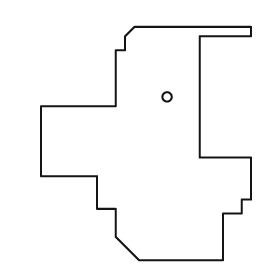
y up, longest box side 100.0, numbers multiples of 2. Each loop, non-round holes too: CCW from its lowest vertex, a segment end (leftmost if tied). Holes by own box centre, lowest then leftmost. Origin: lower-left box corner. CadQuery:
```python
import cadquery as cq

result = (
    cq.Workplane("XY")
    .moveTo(42.0, 0.0)
    .lineTo(78.0, 0.0)
    .lineTo(78.0, 20.0)
    .lineTo(86.0, 20.0)
    .lineTo(86.0, 26.0)
    .lineTo(90.0, 26.0)
    .lineTo(90.0, 44.0)
    .lineTo(68.0, 44.0)
    .lineTo(68.0, 96.0)
    .lineTo(90.0, 96.0)
    .lineTo(90.0, 100.0)
    .lineTo(40.0, 100.0)
    .lineTo(36.0, 96.0)
    .lineTo(36.0, 90.0)
    .lineTo(32.0, 90.0)
    .lineTo(32.0, 66.0)
    .lineTo(0.0, 66.0)
    .lineTo(0.0, 36.0)
    .lineTo(24.0, 36.0)
    .lineTo(24.0, 22.0)
    .lineTo(32.0, 22.0)
    .lineTo(32.0, 10.0)
    .close()
    .moveTo(54.0, 70.0)
    .circle(2.0)
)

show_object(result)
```